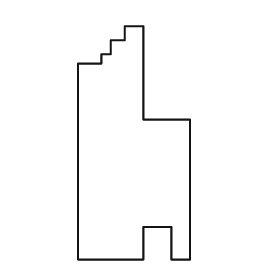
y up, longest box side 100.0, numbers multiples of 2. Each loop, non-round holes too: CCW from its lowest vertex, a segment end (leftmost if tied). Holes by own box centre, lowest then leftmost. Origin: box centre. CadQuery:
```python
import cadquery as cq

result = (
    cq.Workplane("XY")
    .moveTo(-24.0, -50.0)
    .lineTo(4.0, -50.0)
    .lineTo(4.0, -36.0)
    .lineTo(16.0, -36.0)
    .lineTo(16.0, -50.0)
    .lineTo(24.0, -50.0)
    .lineTo(24.0, 10.0)
    .lineTo(4.0, 10.0)
    .lineTo(4.0, 50.0)
    .lineTo(-4.0, 50.0)
    .lineTo(-4.0, 44.0)
    .lineTo(-10.0, 44.0)
    .lineTo(-10.0, 38.0)
    .lineTo(-14.0, 38.0)
    .lineTo(-14.0, 34.0)
    .lineTo(-24.0, 34.0)
    .close()
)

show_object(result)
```